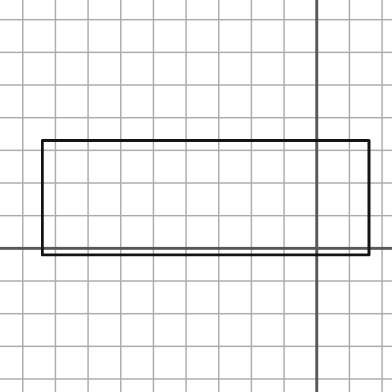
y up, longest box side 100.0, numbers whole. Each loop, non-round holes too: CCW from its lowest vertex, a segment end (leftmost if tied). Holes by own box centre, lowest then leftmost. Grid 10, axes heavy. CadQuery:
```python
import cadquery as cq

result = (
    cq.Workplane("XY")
    .moveTo(-84.0, -2.0)
    .lineTo(16.0, -2.0)
    .lineTo(16.0, 33.0)
    .lineTo(-84.0, 33.0)
    .close()
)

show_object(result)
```